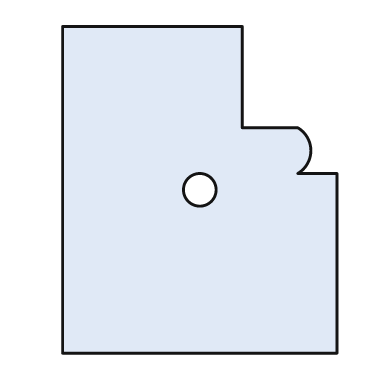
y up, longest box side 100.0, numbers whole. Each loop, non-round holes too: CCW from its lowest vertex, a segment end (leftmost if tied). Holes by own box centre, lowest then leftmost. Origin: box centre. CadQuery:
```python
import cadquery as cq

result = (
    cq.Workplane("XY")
    .moveTo(-42.0, -50.0)
    .lineTo(42.0, -50.0)
    .lineTo(42.0, 5.0)
    .lineTo(30.0, 5.0)
    .threePointArc((34.0, 12.0), (30.0, 19.0))
    .lineTo(13.0, 19.0)
    .lineTo(13.0, 50.0)
    .lineTo(-42.0, 50.0)
    .close()
    .moveTo(0.0, 0.0)
    .circle(5.0)
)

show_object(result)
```